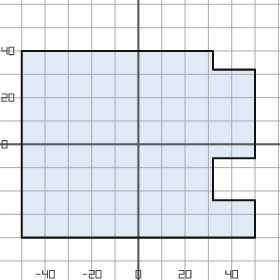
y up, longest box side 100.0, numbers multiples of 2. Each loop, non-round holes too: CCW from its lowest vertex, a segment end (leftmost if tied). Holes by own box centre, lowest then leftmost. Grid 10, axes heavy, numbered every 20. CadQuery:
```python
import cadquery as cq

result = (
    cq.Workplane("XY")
    .moveTo(-50.0, -40.0)
    .lineTo(50.0, -40.0)
    .lineTo(50.0, -24.0)
    .lineTo(32.0, -24.0)
    .lineTo(32.0, -6.0)
    .lineTo(50.0, -6.0)
    .lineTo(50.0, 32.0)
    .lineTo(32.0, 32.0)
    .lineTo(32.0, 40.0)
    .lineTo(-50.0, 40.0)
    .close()
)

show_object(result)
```